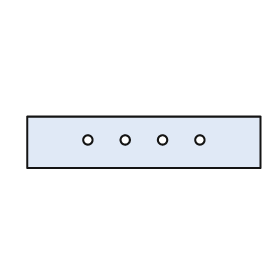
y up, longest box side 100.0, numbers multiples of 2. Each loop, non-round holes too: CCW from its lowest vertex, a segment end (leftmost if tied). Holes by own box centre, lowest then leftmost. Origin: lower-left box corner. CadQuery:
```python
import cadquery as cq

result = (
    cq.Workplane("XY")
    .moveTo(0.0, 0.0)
    .lineTo(100.0, 0.0)
    .lineTo(100.0, 22.0)
    .lineTo(0.0, 22.0)
    .close()
    .moveTo(26.0, 12.0)
    .circle(2.0)
    .moveTo(42.0, 12.0)
    .circle(2.0)
    .moveTo(58.0, 12.0)
    .circle(2.0)
    .moveTo(74.0, 12.0)
    .circle(2.0)
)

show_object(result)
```